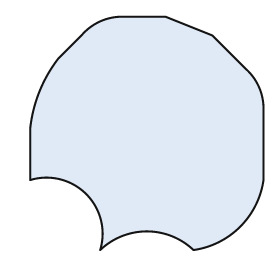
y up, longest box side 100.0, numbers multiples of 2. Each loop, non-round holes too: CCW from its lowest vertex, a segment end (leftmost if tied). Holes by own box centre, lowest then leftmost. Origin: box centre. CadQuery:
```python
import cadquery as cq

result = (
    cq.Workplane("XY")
    .moveTo(-20.0, -50.0)
    .threePointArc((0.0, -42.0), (20.0, -50.0))
    .threePointArc((40.0, -40.0), (50.0, -20.0))
    .lineTo(50.0, 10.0)
    .threePointArc((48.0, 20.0), (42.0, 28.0))
    .lineTo(28.0, 42.0)
    .lineTo(8.0, 50.0)
    .lineTo(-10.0, 50.0)
    .threePointArc((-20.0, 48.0), (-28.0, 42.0))
    .lineTo(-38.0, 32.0)
    .threePointArc((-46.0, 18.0), (-50.0, 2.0))
    .lineTo(-50.0, -20.0)
    .threePointArc((-26.0, -26.0), (-20.0, -50.0))
    .close()
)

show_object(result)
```